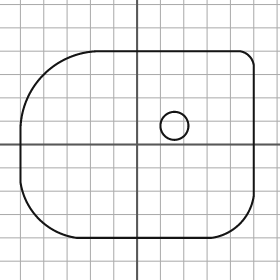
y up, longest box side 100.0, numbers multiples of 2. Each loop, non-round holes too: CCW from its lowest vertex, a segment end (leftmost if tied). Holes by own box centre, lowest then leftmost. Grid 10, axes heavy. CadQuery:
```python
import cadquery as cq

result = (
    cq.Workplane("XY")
    .moveTo(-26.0, -40.0)
    .lineTo(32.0, -40.0)
    .threePointArc((44.0, -34.0), (50.0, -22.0))
    .lineTo(50.0, 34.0)
    .threePointArc((48.0, 38.0), (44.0, 40.0))
    .lineTo(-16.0, 40.0)
    .threePointArc((-40.0, 30.0), (-50.0, 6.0))
    .lineTo(-50.0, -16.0)
    .threePointArc((-42.0, -32.0), (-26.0, -40.0))
    .close()
    .moveTo(16.0, 8.0)
    .circle(6.0)
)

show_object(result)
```